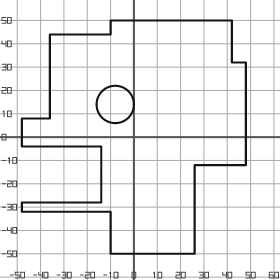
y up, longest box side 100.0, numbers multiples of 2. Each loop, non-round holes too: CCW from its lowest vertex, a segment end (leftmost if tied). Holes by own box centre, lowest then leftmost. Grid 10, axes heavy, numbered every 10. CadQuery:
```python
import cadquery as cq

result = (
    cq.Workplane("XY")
    .moveTo(-10.0, -50.0)
    .lineTo(26.0, -50.0)
    .lineTo(26.0, -12.0)
    .lineTo(48.0, -12.0)
    .lineTo(48.0, 32.0)
    .lineTo(42.0, 32.0)
    .lineTo(42.0, 50.0)
    .lineTo(-10.0, 50.0)
    .lineTo(-10.0, 44.0)
    .lineTo(-36.0, 44.0)
    .lineTo(-36.0, 8.0)
    .lineTo(-48.0, 8.0)
    .lineTo(-48.0, -4.0)
    .lineTo(-14.0, -4.0)
    .lineTo(-14.0, -28.0)
    .lineTo(-48.0, -28.0)
    .lineTo(-48.0, -32.0)
    .lineTo(-10.0, -32.0)
    .close()
    .moveTo(-8.0, 14.0)
    .circle(8.0)
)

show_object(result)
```